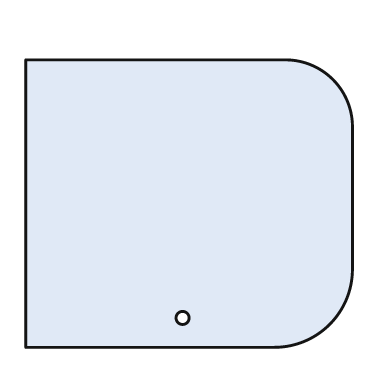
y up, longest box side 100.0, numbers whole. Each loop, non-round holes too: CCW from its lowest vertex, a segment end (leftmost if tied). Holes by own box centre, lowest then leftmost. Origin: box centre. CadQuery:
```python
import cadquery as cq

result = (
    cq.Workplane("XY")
    .moveTo(-50.0, -44.0)
    .lineTo(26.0, -44.0)
    .threePointArc((43.0, -37.0), (50.0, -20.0))
    .lineTo(50.0, 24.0)
    .threePointArc((44.0, 38.0), (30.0, 44.0))
    .lineTo(-50.0, 44.0)
    .close()
    .moveTo(-2.0, -35.0)
    .circle(2.0)
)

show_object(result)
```